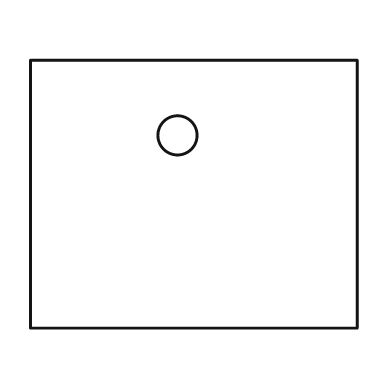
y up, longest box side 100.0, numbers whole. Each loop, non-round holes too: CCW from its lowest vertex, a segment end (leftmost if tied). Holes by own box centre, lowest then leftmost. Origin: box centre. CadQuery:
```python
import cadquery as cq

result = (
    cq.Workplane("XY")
    .moveTo(-50.0, -41.0)
    .lineTo(50.0, -41.0)
    .lineTo(50.0, 41.0)
    .lineTo(-50.0, 41.0)
    .close()
    .moveTo(-5.0, 18.0)
    .circle(6.0)
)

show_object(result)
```